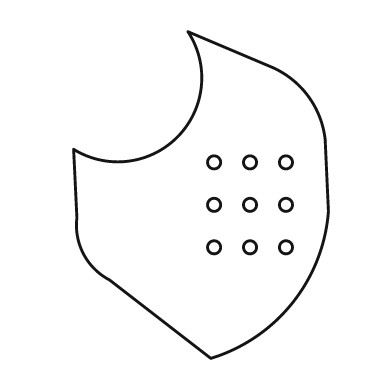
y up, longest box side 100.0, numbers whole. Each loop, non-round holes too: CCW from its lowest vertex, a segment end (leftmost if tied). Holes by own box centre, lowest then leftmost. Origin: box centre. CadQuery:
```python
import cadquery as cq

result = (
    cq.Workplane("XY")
    .moveTo(3.0, -50.0)
    .threePointArc((28.0, -33.0), (39.0, -5.0))
    .lineTo(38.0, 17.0)
    .threePointArc((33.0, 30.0), (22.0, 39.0))
    .lineTo(-4.0, 50.0)
    .threePointArc((-7.0, 18.0), (-39.0, 14.0))
    .lineTo(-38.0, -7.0)
    .threePointArc((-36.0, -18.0), (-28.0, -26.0))
    .close()
    .moveTo(4.0, -16.0)
    .circle(2.0)
    .moveTo(15.0, -16.0)
    .circle(2.0)
    .moveTo(26.0, -16.0)
    .circle(2.0)
    .moveTo(4.0, -3.0)
    .circle(2.0)
    .moveTo(15.0, -3.0)
    .circle(2.0)
    .moveTo(26.0, -3.0)
    .circle(2.0)
    .moveTo(4.0, 10.0)
    .circle(2.0)
    .moveTo(15.0, 10.0)
    .circle(2.0)
    .moveTo(26.0, 10.0)
    .circle(2.0)
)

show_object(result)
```